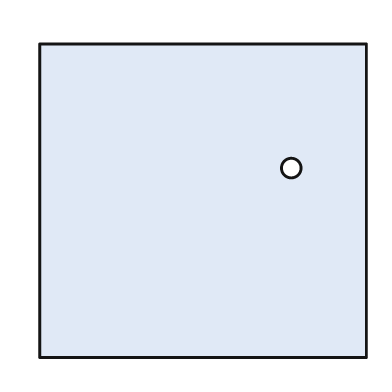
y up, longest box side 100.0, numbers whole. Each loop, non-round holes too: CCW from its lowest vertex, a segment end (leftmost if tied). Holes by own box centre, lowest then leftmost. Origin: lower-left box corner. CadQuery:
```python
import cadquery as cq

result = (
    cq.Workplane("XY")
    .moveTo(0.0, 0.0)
    .lineTo(100.0, 0.0)
    .lineTo(100.0, 96.0)
    .lineTo(0.0, 96.0)
    .close()
    .moveTo(77.0, 58.0)
    .circle(3.0)
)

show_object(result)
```